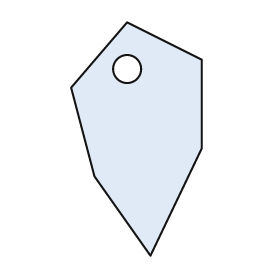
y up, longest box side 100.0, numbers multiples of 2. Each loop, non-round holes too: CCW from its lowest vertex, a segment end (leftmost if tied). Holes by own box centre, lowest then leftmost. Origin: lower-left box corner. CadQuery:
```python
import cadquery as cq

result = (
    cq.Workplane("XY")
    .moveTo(34.0, 0.0)
    .lineTo(56.0, 46.0)
    .lineTo(56.0, 84.0)
    .lineTo(24.0, 100.0)
    .lineTo(0.0, 72.0)
    .lineTo(10.0, 34.0)
    .close()
    .moveTo(24.0, 80.0)
    .circle(6.0)
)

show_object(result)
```